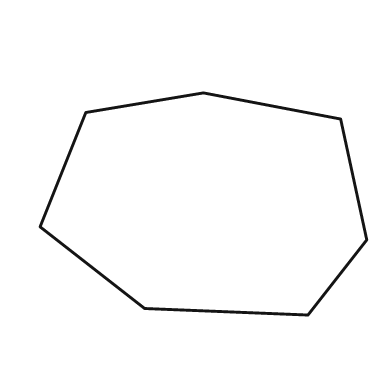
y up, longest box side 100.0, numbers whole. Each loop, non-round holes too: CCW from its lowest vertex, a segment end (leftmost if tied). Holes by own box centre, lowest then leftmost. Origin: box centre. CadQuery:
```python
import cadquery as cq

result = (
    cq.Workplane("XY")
    .moveTo(32.0, -34.0)
    .lineTo(50.0, -11.0)
    .lineTo(42.0, 26.0)
    .lineTo(0.0, 34.0)
    .lineTo(-36.0, 28.0)
    .lineTo(-50.0, -7.0)
    .lineTo(-18.0, -32.0)
    .close()
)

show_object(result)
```